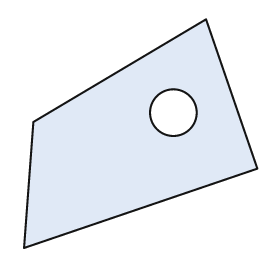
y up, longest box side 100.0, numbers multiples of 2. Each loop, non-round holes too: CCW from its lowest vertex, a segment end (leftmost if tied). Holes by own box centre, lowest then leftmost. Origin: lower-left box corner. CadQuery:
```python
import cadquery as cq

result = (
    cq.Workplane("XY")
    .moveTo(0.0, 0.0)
    .lineTo(100.0, 34.0)
    .lineTo(78.0, 98.0)
    .lineTo(4.0, 54.0)
    .close()
    .moveTo(64.0, 58.0)
    .circle(10.0)
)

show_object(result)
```